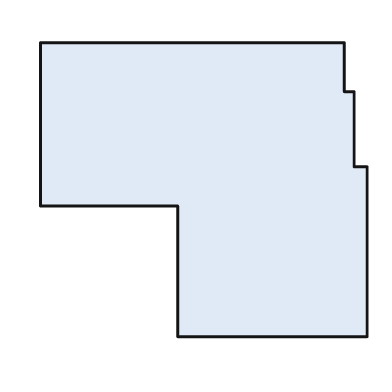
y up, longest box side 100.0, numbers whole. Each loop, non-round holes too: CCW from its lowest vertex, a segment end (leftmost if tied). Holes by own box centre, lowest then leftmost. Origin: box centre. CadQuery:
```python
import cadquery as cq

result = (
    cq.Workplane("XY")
    .moveTo(-8.0, -45.0)
    .lineTo(50.0, -45.0)
    .lineTo(50.0, 7.0)
    .lineTo(46.0, 7.0)
    .lineTo(46.0, 30.0)
    .lineTo(43.0, 30.0)
    .lineTo(43.0, 45.0)
    .lineTo(-50.0, 45.0)
    .lineTo(-50.0, -5.0)
    .lineTo(-8.0, -5.0)
    .close()
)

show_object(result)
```